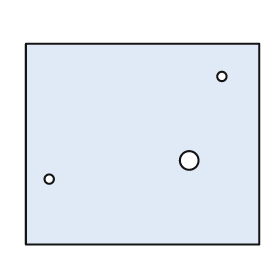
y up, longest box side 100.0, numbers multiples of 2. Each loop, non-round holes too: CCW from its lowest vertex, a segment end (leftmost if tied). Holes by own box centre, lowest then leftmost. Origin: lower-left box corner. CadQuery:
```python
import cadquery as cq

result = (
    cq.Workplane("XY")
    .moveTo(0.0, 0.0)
    .lineTo(100.0, 0.0)
    .lineTo(100.0, 86.0)
    .lineTo(0.0, 86.0)
    .close()
    .moveTo(10.0, 28.0)
    .circle(2.0)
    .moveTo(70.0, 36.0)
    .circle(4.0)
    .moveTo(84.0, 72.0)
    .circle(2.0)
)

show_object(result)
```